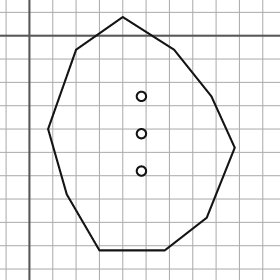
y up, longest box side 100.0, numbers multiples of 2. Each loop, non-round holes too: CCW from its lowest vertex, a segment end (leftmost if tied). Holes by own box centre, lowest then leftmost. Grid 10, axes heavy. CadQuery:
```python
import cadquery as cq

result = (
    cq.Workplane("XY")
    .moveTo(30.0, -92.0)
    .lineTo(58.0, -92.0)
    .lineTo(76.0, -78.0)
    .lineTo(88.0, -48.0)
    .lineTo(78.0, -26.0)
    .lineTo(62.0, -6.0)
    .lineTo(40.0, 8.0)
    .lineTo(20.0, -6.0)
    .lineTo(8.0, -40.0)
    .lineTo(16.0, -68.0)
    .close()
    .moveTo(48.0, -58.0)
    .circle(2.0)
    .moveTo(48.0, -42.0)
    .circle(2.0)
    .moveTo(48.0, -26.0)
    .circle(2.0)
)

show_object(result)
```